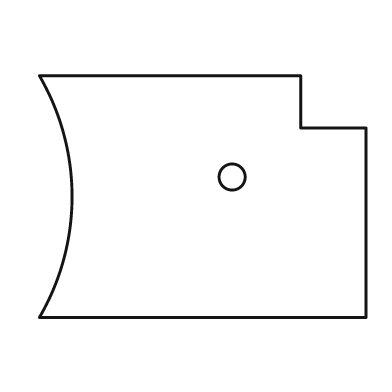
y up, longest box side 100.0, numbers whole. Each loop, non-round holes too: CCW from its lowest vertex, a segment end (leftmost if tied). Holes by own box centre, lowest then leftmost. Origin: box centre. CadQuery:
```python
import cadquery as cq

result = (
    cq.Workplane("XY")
    .moveTo(-50.0, -37.0)
    .lineTo(50.0, -37.0)
    .lineTo(50.0, 21.0)
    .lineTo(30.0, 21.0)
    .lineTo(30.0, 37.0)
    .lineTo(-50.0, 37.0)
    .threePointArc((-40.0, 0.0), (-50.0, -37.0))
    .close()
    .moveTo(9.0, 6.0)
    .circle(4.0)
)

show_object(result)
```